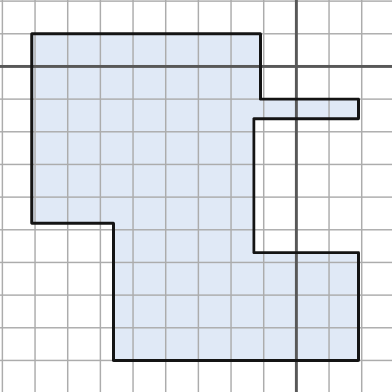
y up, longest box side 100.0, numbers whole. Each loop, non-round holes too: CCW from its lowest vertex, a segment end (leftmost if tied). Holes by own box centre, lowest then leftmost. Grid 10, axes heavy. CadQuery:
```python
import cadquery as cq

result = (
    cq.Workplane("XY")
    .moveTo(-56.0, -90.0)
    .lineTo(19.0, -90.0)
    .lineTo(19.0, -57.0)
    .lineTo(-13.0, -57.0)
    .lineTo(-13.0, -16.0)
    .lineTo(19.0, -16.0)
    .lineTo(19.0, -10.0)
    .lineTo(-11.0, -10.0)
    .lineTo(-11.0, 10.0)
    .lineTo(-81.0, 10.0)
    .lineTo(-81.0, -48.0)
    .lineTo(-56.0, -48.0)
    .close()
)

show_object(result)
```